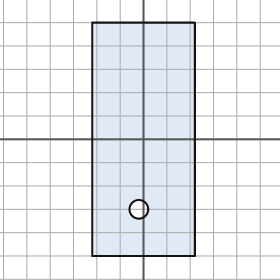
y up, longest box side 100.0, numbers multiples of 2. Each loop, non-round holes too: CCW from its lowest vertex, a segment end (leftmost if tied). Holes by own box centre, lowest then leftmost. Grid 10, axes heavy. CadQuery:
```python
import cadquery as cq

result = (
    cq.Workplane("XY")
    .moveTo(-22.0, -50.0)
    .lineTo(22.0, -50.0)
    .lineTo(22.0, 50.0)
    .lineTo(-22.0, 50.0)
    .close()
    .moveTo(-2.0, -30.0)
    .circle(4.0)
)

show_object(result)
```